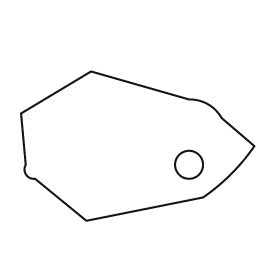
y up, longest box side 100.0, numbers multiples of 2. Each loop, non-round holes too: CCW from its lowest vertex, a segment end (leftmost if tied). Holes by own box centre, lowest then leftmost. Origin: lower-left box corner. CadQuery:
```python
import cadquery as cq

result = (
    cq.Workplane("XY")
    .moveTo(28.0, 0.0)
    .lineTo(78.0, 10.0)
    .threePointArc((90.0, 20.0), (100.0, 32.0))
    .lineTo(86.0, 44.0)
    .threePointArc((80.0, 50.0), (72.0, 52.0))
    .lineTo(30.0, 64.0)
    .lineTo(0.0, 46.0)
    .lineTo(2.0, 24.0)
    .threePointArc((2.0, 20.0), (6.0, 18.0))
    .close()
    .moveTo(72.0, 24.0)
    .circle(6.0)
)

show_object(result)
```